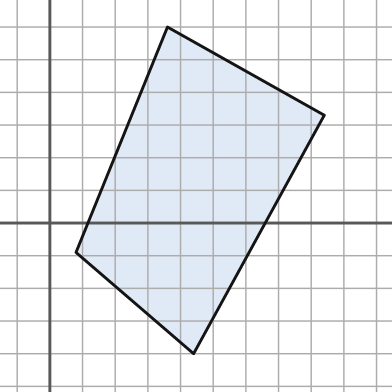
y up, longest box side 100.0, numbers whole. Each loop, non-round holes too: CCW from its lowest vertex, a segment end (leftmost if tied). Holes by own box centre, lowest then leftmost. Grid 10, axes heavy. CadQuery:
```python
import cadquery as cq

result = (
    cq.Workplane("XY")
    .moveTo(44.0, -40.0)
    .lineTo(84.0, 33.0)
    .lineTo(36.0, 60.0)
    .lineTo(8.0, -9.0)
    .close()
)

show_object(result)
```